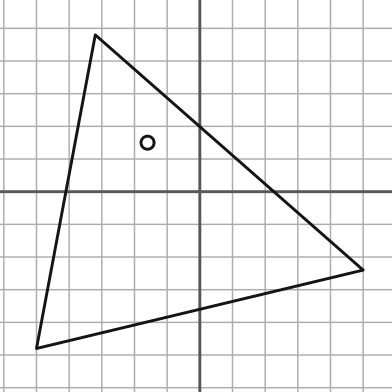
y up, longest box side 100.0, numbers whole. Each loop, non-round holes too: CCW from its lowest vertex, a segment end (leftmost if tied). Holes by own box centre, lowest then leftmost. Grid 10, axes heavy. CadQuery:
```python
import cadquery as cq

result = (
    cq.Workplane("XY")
    .moveTo(-50.0, -48.0)
    .lineTo(50.0, -24.0)
    .lineTo(-32.0, 48.0)
    .close()
    .moveTo(-16.0, 15.0)
    .circle(2.0)
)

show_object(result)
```